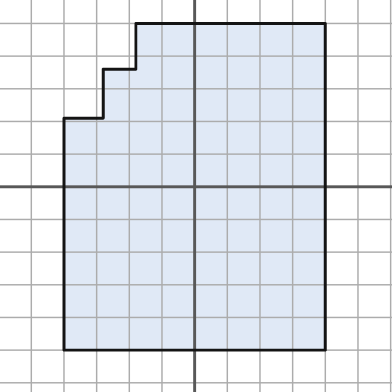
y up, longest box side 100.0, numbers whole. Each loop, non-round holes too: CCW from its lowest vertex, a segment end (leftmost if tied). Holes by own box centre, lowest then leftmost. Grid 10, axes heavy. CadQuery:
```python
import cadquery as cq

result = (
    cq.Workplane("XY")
    .moveTo(-40.0, -50.0)
    .lineTo(40.0, -50.0)
    .lineTo(40.0, 50.0)
    .lineTo(-18.0, 50.0)
    .lineTo(-18.0, 36.0)
    .lineTo(-28.0, 36.0)
    .lineTo(-28.0, 21.0)
    .lineTo(-40.0, 21.0)
    .close()
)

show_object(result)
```